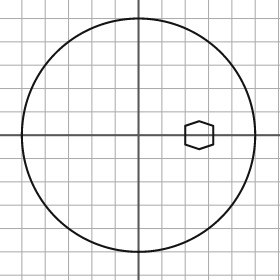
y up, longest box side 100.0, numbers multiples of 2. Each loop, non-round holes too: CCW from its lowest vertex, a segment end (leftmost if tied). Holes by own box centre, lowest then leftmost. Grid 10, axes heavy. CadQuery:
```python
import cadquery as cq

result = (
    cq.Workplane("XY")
    .moveTo(0.0, 0.0)
    .circle(50.0)
    .moveTo(26.0, -6.0)
    .lineTo(32.0, -4.0)
    .lineTo(32.0, 4.0)
    .lineTo(26.0, 6.0)
    .lineTo(20.0, 4.0)
    .lineTo(20.0, -4.0)
    .close()
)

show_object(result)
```